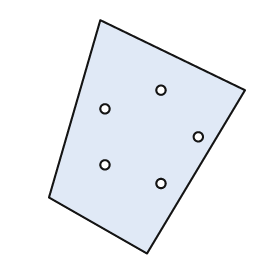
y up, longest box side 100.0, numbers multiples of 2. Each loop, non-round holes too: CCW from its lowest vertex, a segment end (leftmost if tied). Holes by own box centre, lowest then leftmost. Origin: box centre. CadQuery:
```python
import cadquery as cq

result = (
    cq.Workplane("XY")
    .moveTo(0.0, -50.0)
    .lineTo(42.0, 20.0)
    .lineTo(-20.0, 50.0)
    .lineTo(-42.0, -26.0)
    .close()
    .moveTo(6.0, -20.0)
    .circle(2.0)
    .moveTo(-18.0, -12.0)
    .circle(2.0)
    .moveTo(22.0, 0.0)
    .circle(2.0)
    .moveTo(-18.0, 12.0)
    .circle(2.0)
    .moveTo(6.0, 20.0)
    .circle(2.0)
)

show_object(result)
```